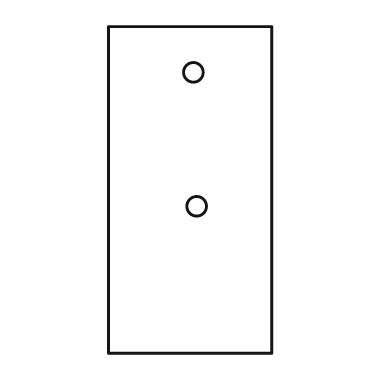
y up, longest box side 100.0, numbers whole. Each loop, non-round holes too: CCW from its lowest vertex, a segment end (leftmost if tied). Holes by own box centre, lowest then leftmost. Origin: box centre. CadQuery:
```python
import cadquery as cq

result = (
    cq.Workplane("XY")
    .moveTo(-25.0, -50.0)
    .lineTo(25.0, -50.0)
    .lineTo(25.0, 50.0)
    .lineTo(-25.0, 50.0)
    .close()
    .moveTo(2.0, -5.0)
    .circle(3.0)
    .moveTo(1.0, 36.0)
    .circle(3.0)
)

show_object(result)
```